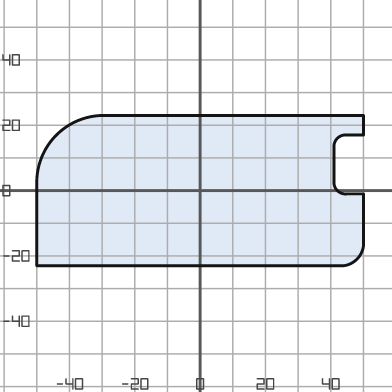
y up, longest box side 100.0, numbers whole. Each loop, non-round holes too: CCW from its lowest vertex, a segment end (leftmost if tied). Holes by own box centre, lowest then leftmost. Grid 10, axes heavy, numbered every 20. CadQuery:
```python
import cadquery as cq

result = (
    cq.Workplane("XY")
    .moveTo(-50.0, -23.0)
    .lineTo(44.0, -23.0)
    .threePointArc((48.0, -21.0), (50.0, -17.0))
    .lineTo(50.0, -1.0)
    .lineTo(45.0, -1.0)
    .threePointArc((42.0, 0.0), (41.0, 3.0))
    .lineTo(41.0, 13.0)
    .threePointArc((42.0, 16.0), (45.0, 17.0))
    .lineTo(50.0, 17.0)
    .lineTo(50.0, 23.0)
    .lineTo(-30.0, 23.0)
    .threePointArc((-44.0, 17.0), (-50.0, 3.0))
    .close()
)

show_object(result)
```